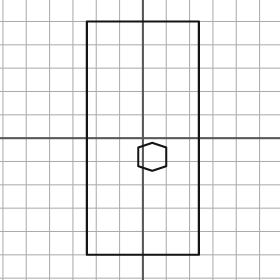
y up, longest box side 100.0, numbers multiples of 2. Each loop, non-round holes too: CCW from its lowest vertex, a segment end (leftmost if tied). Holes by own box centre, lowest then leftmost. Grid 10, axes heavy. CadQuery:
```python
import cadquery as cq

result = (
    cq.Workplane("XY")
    .moveTo(-24.0, -50.0)
    .lineTo(24.0, -50.0)
    .lineTo(24.0, 50.0)
    .lineTo(-24.0, 50.0)
    .close()
    .moveTo(4.0, -14.0)
    .lineTo(10.0, -12.0)
    .lineTo(10.0, -4.0)
    .lineTo(4.0, -2.0)
    .lineTo(-2.0, -4.0)
    .lineTo(-2.0, -12.0)
    .close()
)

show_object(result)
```